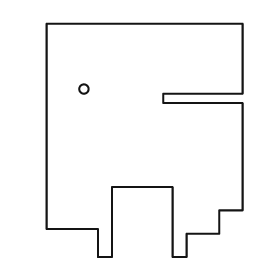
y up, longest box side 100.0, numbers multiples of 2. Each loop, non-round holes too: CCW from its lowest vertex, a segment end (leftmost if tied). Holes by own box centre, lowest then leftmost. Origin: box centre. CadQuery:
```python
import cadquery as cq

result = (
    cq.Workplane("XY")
    .moveTo(-20.0, -50.0)
    .lineTo(-14.0, -50.0)
    .lineTo(-14.0, -20.0)
    .lineTo(12.0, -20.0)
    .lineTo(12.0, -50.0)
    .lineTo(18.0, -50.0)
    .lineTo(18.0, -40.0)
    .lineTo(32.0, -40.0)
    .lineTo(32.0, -30.0)
    .lineTo(42.0, -30.0)
    .lineTo(42.0, 16.0)
    .lineTo(8.0, 16.0)
    .lineTo(8.0, 20.0)
    .lineTo(42.0, 20.0)
    .lineTo(42.0, 50.0)
    .lineTo(-42.0, 50.0)
    .lineTo(-42.0, -38.0)
    .lineTo(-20.0, -38.0)
    .close()
    .moveTo(-26.0, 22.0)
    .circle(2.0)
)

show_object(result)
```